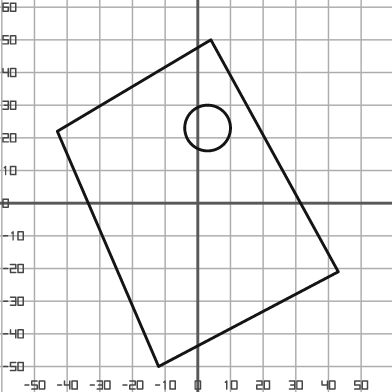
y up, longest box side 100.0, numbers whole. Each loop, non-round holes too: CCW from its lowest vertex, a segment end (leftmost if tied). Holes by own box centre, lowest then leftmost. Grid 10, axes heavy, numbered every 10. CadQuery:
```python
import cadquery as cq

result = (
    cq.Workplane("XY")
    .moveTo(-12.0, -50.0)
    .lineTo(43.0, -21.0)
    .lineTo(4.0, 50.0)
    .lineTo(-43.0, 22.0)
    .close()
    .moveTo(3.0, 23.0)
    .circle(7.0)
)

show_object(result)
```